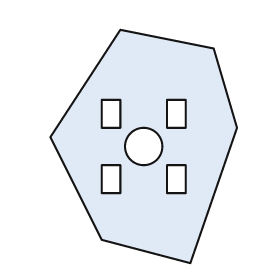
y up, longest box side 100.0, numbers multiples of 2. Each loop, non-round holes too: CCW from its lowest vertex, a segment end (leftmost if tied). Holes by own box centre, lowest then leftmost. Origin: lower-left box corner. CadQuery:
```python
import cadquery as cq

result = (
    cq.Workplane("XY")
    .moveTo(60.0, 0.0)
    .lineTo(80.0, 58.0)
    .lineTo(70.0, 92.0)
    .lineTo(30.0, 100.0)
    .lineTo(0.0, 54.0)
    .lineTo(22.0, 10.0)
    .close()
    .moveTo(22.0, 30.0)
    .lineTo(30.0, 30.0)
    .lineTo(30.0, 42.0)
    .lineTo(22.0, 42.0)
    .close()
    .moveTo(50.0, 30.0)
    .lineTo(58.0, 30.0)
    .lineTo(58.0, 42.0)
    .lineTo(50.0, 42.0)
    .close()
    .moveTo(40.0, 50.0)
    .circle(8.0)
    .moveTo(22.0, 58.0)
    .lineTo(30.0, 58.0)
    .lineTo(30.0, 70.0)
    .lineTo(22.0, 70.0)
    .close()
    .moveTo(50.0, 58.0)
    .lineTo(58.0, 58.0)
    .lineTo(58.0, 70.0)
    .lineTo(50.0, 70.0)
    .close()
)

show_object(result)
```